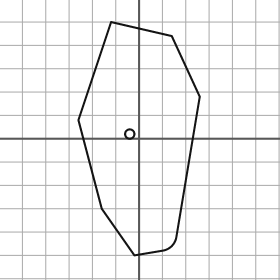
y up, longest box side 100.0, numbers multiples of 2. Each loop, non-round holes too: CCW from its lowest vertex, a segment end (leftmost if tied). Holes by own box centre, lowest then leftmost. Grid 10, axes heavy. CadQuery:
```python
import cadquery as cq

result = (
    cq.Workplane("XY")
    .moveTo(-2.0, -50.0)
    .lineTo(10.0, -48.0)
    .threePointArc((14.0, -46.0), (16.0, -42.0))
    .lineTo(26.0, 18.0)
    .lineTo(14.0, 44.0)
    .lineTo(-12.0, 50.0)
    .lineTo(-26.0, 8.0)
    .lineTo(-16.0, -30.0)
    .close()
    .moveTo(-4.0, 2.0)
    .circle(2.0)
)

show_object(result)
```